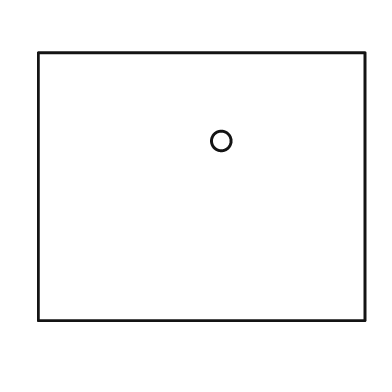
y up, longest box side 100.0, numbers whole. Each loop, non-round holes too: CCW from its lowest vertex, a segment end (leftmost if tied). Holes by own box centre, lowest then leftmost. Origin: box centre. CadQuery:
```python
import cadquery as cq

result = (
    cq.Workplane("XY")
    .moveTo(-50.0, -41.0)
    .lineTo(50.0, -41.0)
    .lineTo(50.0, 41.0)
    .lineTo(-50.0, 41.0)
    .close()
    .moveTo(6.0, 14.0)
    .circle(3.0)
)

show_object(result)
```